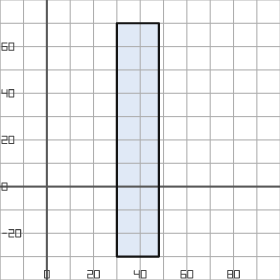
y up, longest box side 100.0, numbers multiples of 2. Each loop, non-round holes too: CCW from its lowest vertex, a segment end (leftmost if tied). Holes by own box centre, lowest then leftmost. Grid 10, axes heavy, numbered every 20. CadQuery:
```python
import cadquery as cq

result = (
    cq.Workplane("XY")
    .moveTo(30.0, -30.0)
    .lineTo(48.0, -30.0)
    .lineTo(48.0, 70.0)
    .lineTo(30.0, 70.0)
    .close()
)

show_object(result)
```